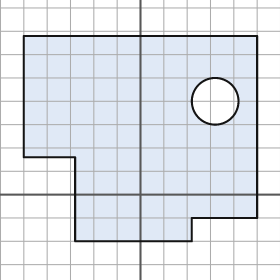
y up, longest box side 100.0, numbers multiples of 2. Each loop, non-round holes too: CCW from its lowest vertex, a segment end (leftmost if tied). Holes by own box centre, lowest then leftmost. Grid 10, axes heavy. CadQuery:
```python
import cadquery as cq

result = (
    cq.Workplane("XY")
    .moveTo(-28.0, -20.0)
    .lineTo(22.0, -20.0)
    .lineTo(22.0, -10.0)
    .lineTo(50.0, -10.0)
    .lineTo(50.0, 68.0)
    .lineTo(-50.0, 68.0)
    .lineTo(-50.0, 16.0)
    .lineTo(-28.0, 16.0)
    .close()
    .moveTo(32.0, 40.0)
    .circle(10.0)
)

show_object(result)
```